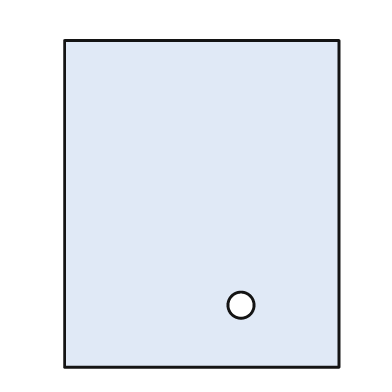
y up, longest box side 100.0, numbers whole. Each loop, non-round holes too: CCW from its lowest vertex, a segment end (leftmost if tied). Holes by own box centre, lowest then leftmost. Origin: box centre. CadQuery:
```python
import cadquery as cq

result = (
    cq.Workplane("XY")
    .moveTo(-42.0, -50.0)
    .lineTo(42.0, -50.0)
    .lineTo(42.0, 50.0)
    .lineTo(-42.0, 50.0)
    .close()
    .moveTo(12.0, -31.0)
    .circle(4.0)
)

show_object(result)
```